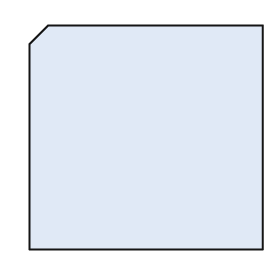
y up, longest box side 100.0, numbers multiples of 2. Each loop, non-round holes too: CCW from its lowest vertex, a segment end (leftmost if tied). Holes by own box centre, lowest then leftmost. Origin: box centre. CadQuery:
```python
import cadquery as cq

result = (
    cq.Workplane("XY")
    .moveTo(-50.0, -48.0)
    .lineTo(50.0, -48.0)
    .lineTo(50.0, 48.0)
    .lineTo(-42.0, 48.0)
    .lineTo(-50.0, 40.0)
    .close()
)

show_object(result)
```